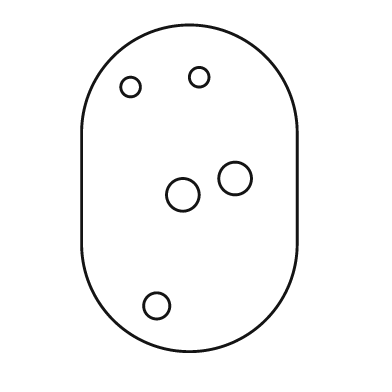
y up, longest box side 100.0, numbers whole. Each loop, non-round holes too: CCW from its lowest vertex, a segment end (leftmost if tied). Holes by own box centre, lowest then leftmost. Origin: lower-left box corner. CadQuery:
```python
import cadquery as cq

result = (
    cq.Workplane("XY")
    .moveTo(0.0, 33.0)
    .threePointArc((33.0, 0.0), (66.0, 33.0))
    .lineTo(66.0, 67.0)
    .threePointArc((33.0, 100.0), (0.0, 67.0))
    .close()
    .moveTo(23.0, 14.0)
    .circle(4.0)
    .moveTo(31.0, 48.0)
    .circle(5.0)
    .moveTo(47.0, 53.0)
    .circle(5.0)
    .moveTo(15.0, 81.0)
    .circle(3.0)
    .moveTo(36.0, 84.0)
    .circle(3.0)
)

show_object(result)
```